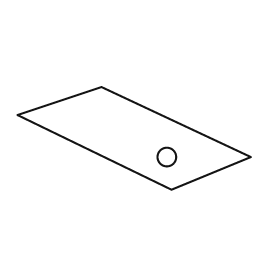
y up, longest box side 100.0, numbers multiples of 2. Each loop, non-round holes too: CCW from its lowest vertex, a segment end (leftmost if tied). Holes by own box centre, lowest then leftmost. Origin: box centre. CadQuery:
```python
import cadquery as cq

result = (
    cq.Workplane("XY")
    .moveTo(16.0, -22.0)
    .lineTo(50.0, -8.0)
    .lineTo(-14.0, 22.0)
    .lineTo(-50.0, 10.0)
    .close()
    .moveTo(14.0, -8.0)
    .circle(4.0)
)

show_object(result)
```